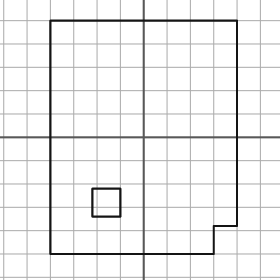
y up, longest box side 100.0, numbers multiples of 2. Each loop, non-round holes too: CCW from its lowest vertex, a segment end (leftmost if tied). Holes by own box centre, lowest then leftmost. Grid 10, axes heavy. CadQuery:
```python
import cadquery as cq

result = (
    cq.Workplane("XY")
    .moveTo(-40.0, -50.0)
    .lineTo(30.0, -50.0)
    .lineTo(30.0, -38.0)
    .lineTo(40.0, -38.0)
    .lineTo(40.0, 50.0)
    .lineTo(-40.0, 50.0)
    .close()
    .moveTo(-22.0, -34.0)
    .lineTo(-10.0, -34.0)
    .lineTo(-10.0, -22.0)
    .lineTo(-22.0, -22.0)
    .close()
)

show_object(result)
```